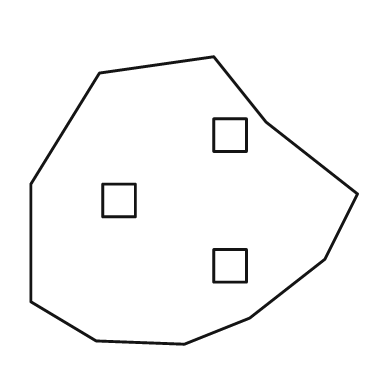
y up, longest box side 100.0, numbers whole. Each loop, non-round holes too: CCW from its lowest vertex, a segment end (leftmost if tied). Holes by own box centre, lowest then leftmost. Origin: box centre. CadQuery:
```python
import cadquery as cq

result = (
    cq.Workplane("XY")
    .moveTo(-3.0, -44.0)
    .lineTo(17.0, -36.0)
    .lineTo(40.0, -18.0)
    .lineTo(50.0, 2.0)
    .lineTo(22.0, 24.0)
    .lineTo(6.0, 44.0)
    .lineTo(-29.0, 39.0)
    .lineTo(-50.0, 5.0)
    .lineTo(-50.0, -31.0)
    .lineTo(-30.0, -43.0)
    .close()
    .moveTo(6.0, -25.0)
    .lineTo(16.0, -25.0)
    .lineTo(16.0, -15.0)
    .lineTo(6.0, -15.0)
    .close()
    .moveTo(-28.0, -5.0)
    .lineTo(-18.0, -5.0)
    .lineTo(-18.0, 5.0)
    .lineTo(-28.0, 5.0)
    .close()
    .moveTo(6.0, 15.0)
    .lineTo(16.0, 15.0)
    .lineTo(16.0, 25.0)
    .lineTo(6.0, 25.0)
    .close()
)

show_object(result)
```